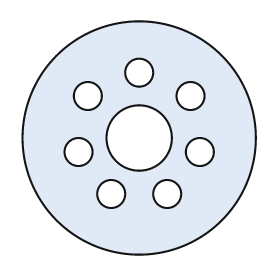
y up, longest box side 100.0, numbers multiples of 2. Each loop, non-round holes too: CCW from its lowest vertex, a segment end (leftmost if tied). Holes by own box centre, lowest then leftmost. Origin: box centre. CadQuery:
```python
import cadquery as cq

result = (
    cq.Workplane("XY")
    .moveTo(0.0, 0.0)
    .circle(50.0)
    .moveTo(-12.0, -24.0)
    .circle(6.0)
    .moveTo(12.0, -24.0)
    .circle(6.0)
    .moveTo(-26.0, -6.0)
    .circle(6.0)
    .moveTo(26.0, -6.0)
    .circle(6.0)
    .moveTo(0.0, 0.0)
    .circle(14.0)
    .moveTo(-22.0, 18.0)
    .circle(6.0)
    .moveTo(22.0, 18.0)
    .circle(6.0)
    .moveTo(0.0, 28.0)
    .circle(6.0)
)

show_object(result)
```